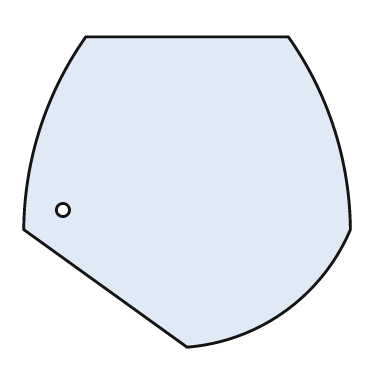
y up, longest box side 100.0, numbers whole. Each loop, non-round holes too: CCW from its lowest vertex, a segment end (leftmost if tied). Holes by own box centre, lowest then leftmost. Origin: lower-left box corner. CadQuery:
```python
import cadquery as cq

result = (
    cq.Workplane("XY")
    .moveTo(50.0, 0.0)
    .threePointArc((80.0, 11.0), (100.0, 36.0))
    .threePointArc((95.0, 67.0), (81.0, 95.0))
    .lineTo(19.0, 95.0)
    .threePointArc((5.0, 67.0), (0.0, 36.0))
    .close()
    .moveTo(12.0, 42.0)
    .circle(2.0)
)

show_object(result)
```